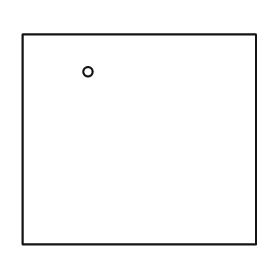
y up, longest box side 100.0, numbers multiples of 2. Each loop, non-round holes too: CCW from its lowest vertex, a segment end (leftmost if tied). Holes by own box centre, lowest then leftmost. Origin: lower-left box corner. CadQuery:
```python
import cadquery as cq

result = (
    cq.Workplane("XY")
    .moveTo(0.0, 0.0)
    .lineTo(100.0, 0.0)
    .lineTo(100.0, 90.0)
    .lineTo(0.0, 90.0)
    .close()
    .moveTo(28.0, 74.0)
    .circle(2.0)
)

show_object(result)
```